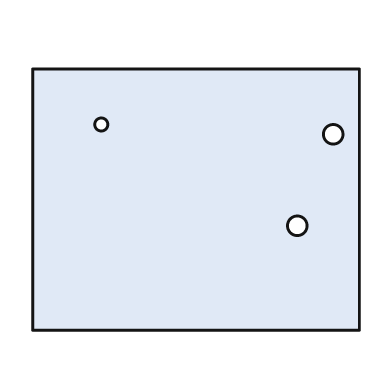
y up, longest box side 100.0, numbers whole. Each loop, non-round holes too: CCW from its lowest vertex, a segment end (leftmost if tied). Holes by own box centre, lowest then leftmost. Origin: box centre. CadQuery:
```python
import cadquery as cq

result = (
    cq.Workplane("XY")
    .moveTo(-50.0, -40.0)
    .lineTo(50.0, -40.0)
    .lineTo(50.0, 40.0)
    .lineTo(-50.0, 40.0)
    .close()
    .moveTo(31.0, -8.0)
    .circle(3.0)
    .moveTo(42.0, 20.0)
    .circle(3.0)
    .moveTo(-29.0, 23.0)
    .circle(2.0)
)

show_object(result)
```